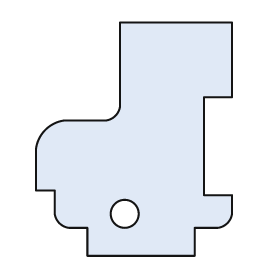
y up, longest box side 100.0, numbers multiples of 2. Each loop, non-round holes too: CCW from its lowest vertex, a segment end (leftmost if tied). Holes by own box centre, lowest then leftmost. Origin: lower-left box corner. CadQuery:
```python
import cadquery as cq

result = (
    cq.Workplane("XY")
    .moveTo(22.0, 0.0)
    .lineTo(68.0, 0.0)
    .lineTo(68.0, 12.0)
    .lineTo(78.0, 12.0)
    .threePointArc((82.0, 14.0), (84.0, 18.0))
    .lineTo(84.0, 26.0)
    .lineTo(72.0, 26.0)
    .lineTo(72.0, 68.0)
    .lineTo(84.0, 68.0)
    .lineTo(84.0, 100.0)
    .lineTo(36.0, 100.0)
    .lineTo(36.0, 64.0)
    .threePointArc((34.0, 60.0), (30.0, 58.0))
    .lineTo(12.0, 58.0)
    .threePointArc((4.0, 54.0), (0.0, 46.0))
    .lineTo(0.0, 28.0)
    .lineTo(8.0, 28.0)
    .lineTo(8.0, 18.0)
    .threePointArc((10.0, 14.0), (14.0, 12.0))
    .lineTo(22.0, 12.0)
    .close()
    .moveTo(38.0, 18.0)
    .circle(6.0)
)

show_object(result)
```